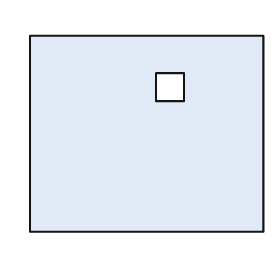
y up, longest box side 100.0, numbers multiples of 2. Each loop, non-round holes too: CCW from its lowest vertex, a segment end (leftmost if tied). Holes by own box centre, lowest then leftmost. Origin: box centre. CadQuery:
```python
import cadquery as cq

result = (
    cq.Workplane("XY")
    .moveTo(-50.0, -42.0)
    .lineTo(50.0, -42.0)
    .lineTo(50.0, 42.0)
    .lineTo(-50.0, 42.0)
    .close()
    .moveTo(4.0, 14.0)
    .lineTo(16.0, 14.0)
    .lineTo(16.0, 26.0)
    .lineTo(4.0, 26.0)
    .close()
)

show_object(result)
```